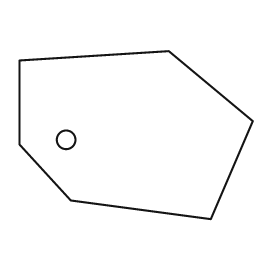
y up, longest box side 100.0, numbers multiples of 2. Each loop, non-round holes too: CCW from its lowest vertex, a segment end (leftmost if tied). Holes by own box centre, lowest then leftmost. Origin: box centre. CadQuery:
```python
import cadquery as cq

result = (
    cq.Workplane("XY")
    .moveTo(32.0, -36.0)
    .lineTo(50.0, 6.0)
    .lineTo(14.0, 36.0)
    .lineTo(-50.0, 32.0)
    .lineTo(-50.0, -4.0)
    .lineTo(-28.0, -28.0)
    .close()
    .moveTo(-30.0, -2.0)
    .circle(4.0)
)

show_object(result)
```